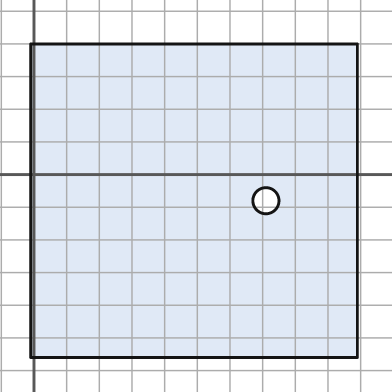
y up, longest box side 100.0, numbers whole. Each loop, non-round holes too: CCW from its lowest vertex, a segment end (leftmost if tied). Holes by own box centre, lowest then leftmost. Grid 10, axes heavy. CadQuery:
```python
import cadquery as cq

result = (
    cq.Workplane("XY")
    .moveTo(-1.0, -56.0)
    .lineTo(99.0, -56.0)
    .lineTo(99.0, 40.0)
    .lineTo(-1.0, 40.0)
    .close()
    .moveTo(71.0, -8.0)
    .circle(4.0)
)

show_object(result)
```